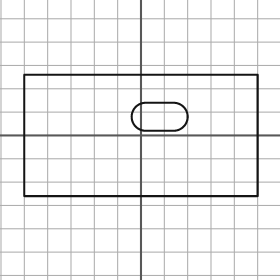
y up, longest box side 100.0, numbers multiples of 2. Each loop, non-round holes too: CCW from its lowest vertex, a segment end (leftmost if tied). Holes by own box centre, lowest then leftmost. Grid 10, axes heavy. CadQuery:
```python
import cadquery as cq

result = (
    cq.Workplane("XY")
    .moveTo(-50.0, -26.0)
    .lineTo(50.0, -26.0)
    .lineTo(50.0, 26.0)
    .lineTo(-50.0, 26.0)
    .close()
    .moveTo(2.0, 2.0)
    .lineTo(14.0, 2.0)
    .threePointArc((20.0, 8.0), (14.0, 14.0))
    .lineTo(2.0, 14.0)
    .threePointArc((-4.0, 8.0), (2.0, 2.0))
    .close()
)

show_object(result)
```